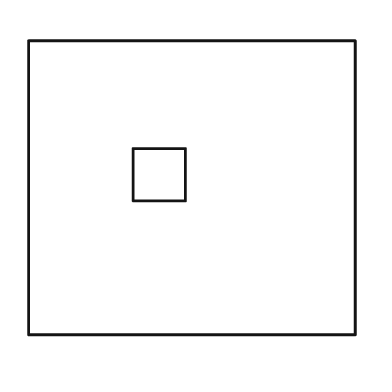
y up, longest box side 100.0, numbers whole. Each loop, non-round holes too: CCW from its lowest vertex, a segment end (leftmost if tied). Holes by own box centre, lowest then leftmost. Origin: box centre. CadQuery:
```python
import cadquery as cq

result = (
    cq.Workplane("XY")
    .moveTo(-50.0, -45.0)
    .lineTo(50.0, -45.0)
    .lineTo(50.0, 45.0)
    .lineTo(-50.0, 45.0)
    .close()
    .moveTo(-18.0, -4.0)
    .lineTo(-2.0, -4.0)
    .lineTo(-2.0, 12.0)
    .lineTo(-18.0, 12.0)
    .close()
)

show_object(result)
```